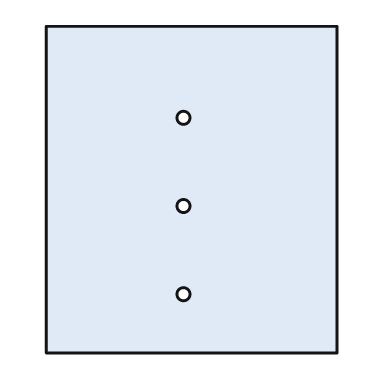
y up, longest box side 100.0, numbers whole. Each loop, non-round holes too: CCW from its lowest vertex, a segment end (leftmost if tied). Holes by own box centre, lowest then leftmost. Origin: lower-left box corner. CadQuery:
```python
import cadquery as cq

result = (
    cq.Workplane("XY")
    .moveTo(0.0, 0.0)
    .lineTo(89.0, 0.0)
    .lineTo(89.0, 100.0)
    .lineTo(0.0, 100.0)
    .close()
    .moveTo(42.0, 18.0)
    .circle(2.0)
    .moveTo(42.0, 45.0)
    .circle(2.0)
    .moveTo(42.0, 72.0)
    .circle(2.0)
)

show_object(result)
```